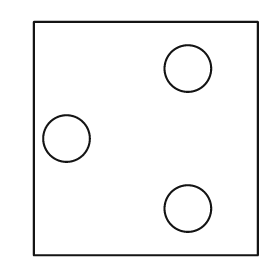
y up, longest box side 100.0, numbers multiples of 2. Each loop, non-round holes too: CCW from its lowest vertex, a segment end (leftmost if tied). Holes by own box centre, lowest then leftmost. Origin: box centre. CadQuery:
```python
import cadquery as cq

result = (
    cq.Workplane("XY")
    .moveTo(-48.0, -50.0)
    .lineTo(48.0, -50.0)
    .lineTo(48.0, 50.0)
    .lineTo(-48.0, 50.0)
    .close()
    .moveTo(18.0, -30.0)
    .circle(10.0)
    .moveTo(-34.0, 0.0)
    .circle(10.0)
    .moveTo(18.0, 30.0)
    .circle(10.0)
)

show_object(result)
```